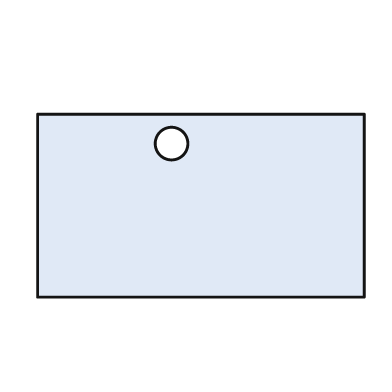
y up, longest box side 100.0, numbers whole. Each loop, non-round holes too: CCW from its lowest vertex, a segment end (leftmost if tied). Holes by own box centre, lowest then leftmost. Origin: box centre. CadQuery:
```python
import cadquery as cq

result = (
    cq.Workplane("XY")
    .moveTo(-50.0, -28.0)
    .lineTo(50.0, -28.0)
    .lineTo(50.0, 28.0)
    .lineTo(-50.0, 28.0)
    .close()
    .moveTo(-9.0, 19.0)
    .circle(5.0)
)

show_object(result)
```